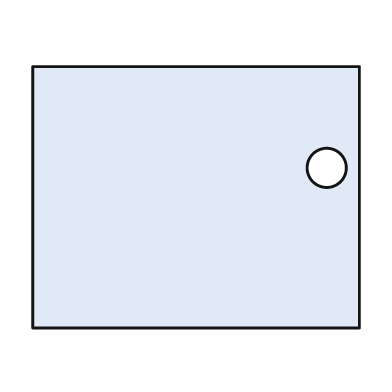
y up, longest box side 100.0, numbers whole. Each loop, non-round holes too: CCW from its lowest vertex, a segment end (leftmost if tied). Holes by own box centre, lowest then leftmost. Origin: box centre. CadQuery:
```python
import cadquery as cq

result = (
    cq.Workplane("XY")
    .moveTo(-50.0, -40.0)
    .lineTo(50.0, -40.0)
    .lineTo(50.0, 40.0)
    .lineTo(-50.0, 40.0)
    .close()
    .moveTo(40.0, 9.0)
    .circle(6.0)
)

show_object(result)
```